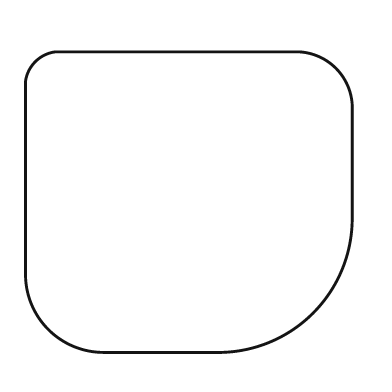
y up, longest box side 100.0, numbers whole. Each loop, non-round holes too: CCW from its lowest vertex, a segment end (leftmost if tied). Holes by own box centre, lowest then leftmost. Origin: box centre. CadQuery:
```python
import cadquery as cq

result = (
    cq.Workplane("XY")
    .moveTo(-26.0, -46.0)
    .lineTo(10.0, -46.0)
    .threePointArc((38.0, -34.0), (50.0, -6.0))
    .lineTo(50.0, 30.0)
    .threePointArc((45.0, 41.0), (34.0, 46.0))
    .lineTo(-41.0, 46.0)
    .threePointArc((-47.0, 43.0), (-50.0, 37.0))
    .lineTo(-50.0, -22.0)
    .threePointArc((-43.0, -39.0), (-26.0, -46.0))
    .close()
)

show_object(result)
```